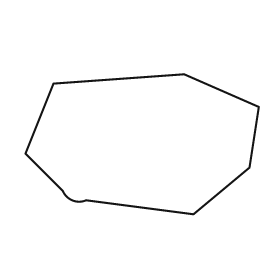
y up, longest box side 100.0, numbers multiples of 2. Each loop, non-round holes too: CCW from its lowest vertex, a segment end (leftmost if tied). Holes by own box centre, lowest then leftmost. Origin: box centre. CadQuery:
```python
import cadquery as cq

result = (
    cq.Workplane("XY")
    .moveTo(22.0, -30.0)
    .lineTo(46.0, -10.0)
    .lineTo(50.0, 16.0)
    .lineTo(18.0, 30.0)
    .lineTo(-38.0, 26.0)
    .lineTo(-50.0, -4.0)
    .lineTo(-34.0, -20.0)
    .threePointArc((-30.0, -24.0), (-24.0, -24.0))
    .close()
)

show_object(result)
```